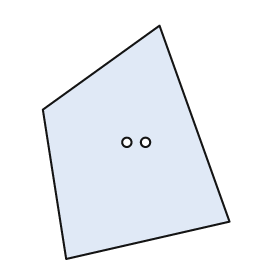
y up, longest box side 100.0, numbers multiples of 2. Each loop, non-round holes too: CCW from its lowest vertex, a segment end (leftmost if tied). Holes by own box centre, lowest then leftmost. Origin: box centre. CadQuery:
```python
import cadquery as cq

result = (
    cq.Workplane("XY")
    .moveTo(-30.0, -50.0)
    .lineTo(40.0, -34.0)
    .lineTo(10.0, 50.0)
    .lineTo(-40.0, 14.0)
    .close()
    .moveTo(-4.0, 0.0)
    .circle(2.0)
    .moveTo(4.0, 0.0)
    .circle(2.0)
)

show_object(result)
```